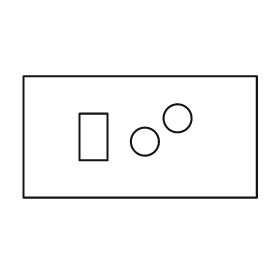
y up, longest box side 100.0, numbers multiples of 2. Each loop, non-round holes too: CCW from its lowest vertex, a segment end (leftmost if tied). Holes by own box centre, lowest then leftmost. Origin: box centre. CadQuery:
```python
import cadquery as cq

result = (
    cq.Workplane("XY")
    .moveTo(-50.0, -26.0)
    .lineTo(50.0, -26.0)
    .lineTo(50.0, 26.0)
    .lineTo(-50.0, 26.0)
    .close()
    .moveTo(2.0, -2.0)
    .circle(6.0)
    .moveTo(-26.0, -10.0)
    .lineTo(-14.0, -10.0)
    .lineTo(-14.0, 10.0)
    .lineTo(-26.0, 10.0)
    .close()
    .moveTo(16.0, 8.0)
    .circle(6.0)
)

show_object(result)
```